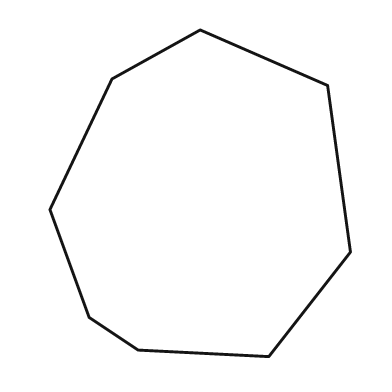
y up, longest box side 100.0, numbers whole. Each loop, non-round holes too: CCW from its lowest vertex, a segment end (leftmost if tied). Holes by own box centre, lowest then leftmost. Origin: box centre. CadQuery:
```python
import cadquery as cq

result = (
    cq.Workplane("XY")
    .moveTo(21.0, -50.0)
    .lineTo(46.0, -18.0)
    .lineTo(39.0, 33.0)
    .lineTo(0.0, 50.0)
    .lineTo(-27.0, 35.0)
    .lineTo(-46.0, -5.0)
    .lineTo(-34.0, -38.0)
    .lineTo(-19.0, -48.0)
    .close()
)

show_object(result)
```